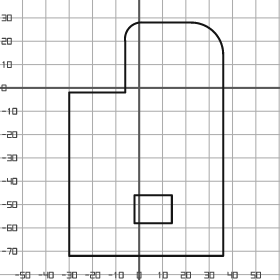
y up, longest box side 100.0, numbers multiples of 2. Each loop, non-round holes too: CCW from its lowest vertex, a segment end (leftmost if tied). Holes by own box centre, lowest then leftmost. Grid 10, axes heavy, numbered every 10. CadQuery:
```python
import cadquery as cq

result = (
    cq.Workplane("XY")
    .moveTo(-30.0, -72.0)
    .lineTo(36.0, -72.0)
    .lineTo(36.0, 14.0)
    .threePointArc((32.0, 24.0), (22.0, 28.0))
    .lineTo(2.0, 28.0)
    .threePointArc((-4.0, 26.0), (-6.0, 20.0))
    .lineTo(-6.0, -2.0)
    .lineTo(-30.0, -2.0)
    .close()
    .moveTo(-2.0, -58.0)
    .lineTo(14.0, -58.0)
    .lineTo(14.0, -46.0)
    .lineTo(-2.0, -46.0)
    .close()
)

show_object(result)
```